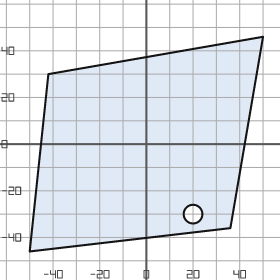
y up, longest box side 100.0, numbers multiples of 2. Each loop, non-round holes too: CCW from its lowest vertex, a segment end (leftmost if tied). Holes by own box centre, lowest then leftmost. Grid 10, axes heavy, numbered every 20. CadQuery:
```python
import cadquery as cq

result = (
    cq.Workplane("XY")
    .moveTo(-50.0, -46.0)
    .lineTo(36.0, -36.0)
    .lineTo(50.0, 46.0)
    .lineTo(-42.0, 30.0)
    .close()
    .moveTo(20.0, -30.0)
    .circle(4.0)
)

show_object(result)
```